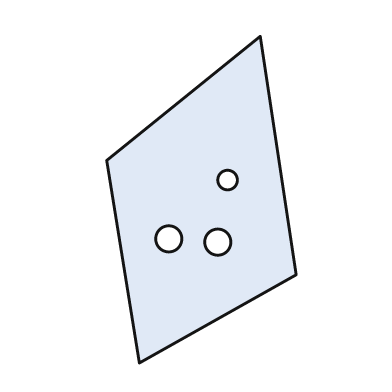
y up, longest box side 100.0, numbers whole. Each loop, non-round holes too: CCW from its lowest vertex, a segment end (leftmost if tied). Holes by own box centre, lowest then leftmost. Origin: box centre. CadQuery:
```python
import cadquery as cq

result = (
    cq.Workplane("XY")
    .moveTo(-19.0, -50.0)
    .lineTo(29.0, -23.0)
    .lineTo(18.0, 50.0)
    .lineTo(-29.0, 12.0)
    .close()
    .moveTo(5.0, -13.0)
    .circle(4.0)
    .moveTo(-10.0, -12.0)
    .circle(4.0)
    .moveTo(8.0, 6.0)
    .circle(3.0)
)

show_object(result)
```